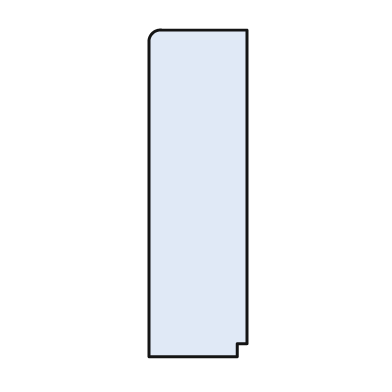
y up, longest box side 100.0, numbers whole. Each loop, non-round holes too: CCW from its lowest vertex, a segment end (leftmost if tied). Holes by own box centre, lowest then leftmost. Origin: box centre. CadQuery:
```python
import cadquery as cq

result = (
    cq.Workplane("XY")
    .moveTo(-15.0, -50.0)
    .lineTo(12.0, -50.0)
    .lineTo(12.0, -46.0)
    .lineTo(15.0, -46.0)
    .lineTo(15.0, 50.0)
    .lineTo(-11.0, 50.0)
    .threePointArc((-14.0, 49.0), (-15.0, 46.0))
    .close()
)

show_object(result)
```